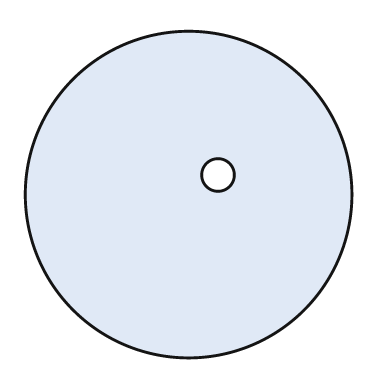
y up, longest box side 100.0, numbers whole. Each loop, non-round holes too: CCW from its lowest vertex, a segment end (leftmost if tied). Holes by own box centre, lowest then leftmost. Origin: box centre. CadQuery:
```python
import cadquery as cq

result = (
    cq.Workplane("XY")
    .moveTo(0.0, 0.0)
    .circle(50.0)
    .moveTo(9.0, 6.0)
    .circle(5.0)
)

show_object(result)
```